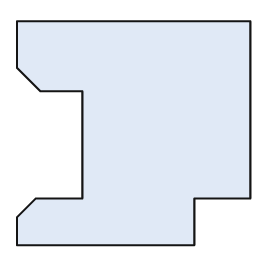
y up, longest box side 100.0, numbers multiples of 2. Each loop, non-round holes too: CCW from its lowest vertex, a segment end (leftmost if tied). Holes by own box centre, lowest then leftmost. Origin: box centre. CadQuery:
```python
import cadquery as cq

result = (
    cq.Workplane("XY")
    .moveTo(-50.0, -48.0)
    .lineTo(26.0, -48.0)
    .lineTo(26.0, -28.0)
    .lineTo(50.0, -28.0)
    .lineTo(50.0, 48.0)
    .lineTo(-50.0, 48.0)
    .lineTo(-50.0, 28.0)
    .lineTo(-40.0, 18.0)
    .lineTo(-22.0, 18.0)
    .lineTo(-22.0, -28.0)
    .lineTo(-42.0, -28.0)
    .lineTo(-50.0, -36.0)
    .close()
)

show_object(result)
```